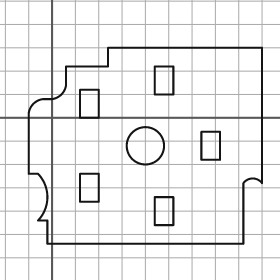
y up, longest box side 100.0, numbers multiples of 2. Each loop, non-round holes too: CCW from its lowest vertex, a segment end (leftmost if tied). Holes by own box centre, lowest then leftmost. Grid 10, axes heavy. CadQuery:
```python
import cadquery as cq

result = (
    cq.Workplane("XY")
    .moveTo(-2.0, -54.0)
    .lineTo(82.0, -54.0)
    .lineTo(82.0, -28.0)
    .threePointArc((86.0, -26.0), (90.0, -28.0))
    .lineTo(90.0, 30.0)
    .lineTo(24.0, 30.0)
    .lineTo(24.0, 22.0)
    .lineTo(6.0, 22.0)
    .lineTo(6.0, 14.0)
    .threePointArc((4.0, 10.0), (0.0, 8.0))
    .lineTo(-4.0, 8.0)
    .threePointArc((-8.0, 6.0), (-10.0, 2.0))
    .lineTo(-10.0, -24.0)
    .lineTo(-6.0, -24.0)
    .threePointArc((-2.0, -34.0), (-6.0, -44.0))
    .lineTo(-2.0, -44.0)
    .close()
    .moveTo(44.0, -46.0)
    .lineTo(52.0, -46.0)
    .lineTo(52.0, -34.0)
    .lineTo(44.0, -34.0)
    .close()
    .moveTo(12.0, -36.0)
    .lineTo(20.0, -36.0)
    .lineTo(20.0, -24.0)
    .lineTo(12.0, -24.0)
    .close()
    .moveTo(40.0, -12.0)
    .circle(8.0)
    .moveTo(64.0, -18.0)
    .lineTo(72.0, -18.0)
    .lineTo(72.0, -6.0)
    .lineTo(64.0, -6.0)
    .close()
    .moveTo(12.0, 0.0)
    .lineTo(20.0, 0.0)
    .lineTo(20.0, 12.0)
    .lineTo(12.0, 12.0)
    .close()
    .moveTo(44.0, 10.0)
    .lineTo(52.0, 10.0)
    .lineTo(52.0, 22.0)
    .lineTo(44.0, 22.0)
    .close()
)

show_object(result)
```